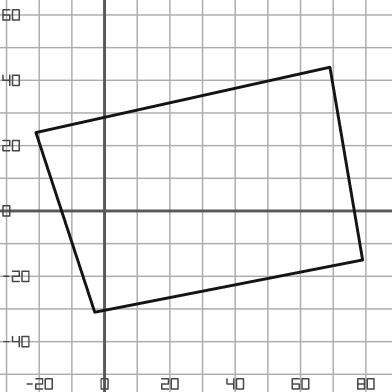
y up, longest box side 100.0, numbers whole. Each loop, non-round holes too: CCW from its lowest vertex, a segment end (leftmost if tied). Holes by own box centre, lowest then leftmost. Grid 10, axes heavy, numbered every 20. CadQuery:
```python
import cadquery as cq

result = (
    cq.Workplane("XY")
    .moveTo(-3.0, -31.0)
    .lineTo(79.0, -15.0)
    .lineTo(69.0, 44.0)
    .lineTo(-21.0, 24.0)
    .close()
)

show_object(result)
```